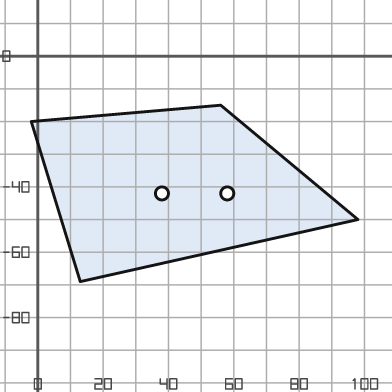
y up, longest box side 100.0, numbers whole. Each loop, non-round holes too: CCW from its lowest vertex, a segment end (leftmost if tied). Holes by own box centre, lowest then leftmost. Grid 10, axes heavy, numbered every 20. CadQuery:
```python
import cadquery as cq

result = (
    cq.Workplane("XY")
    .moveTo(13.0, -69.0)
    .lineTo(98.0, -50.0)
    .lineTo(56.0, -15.0)
    .lineTo(-2.0, -20.0)
    .close()
    .moveTo(38.0, -42.0)
    .circle(2.0)
    .moveTo(58.0, -42.0)
    .circle(2.0)
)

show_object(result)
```